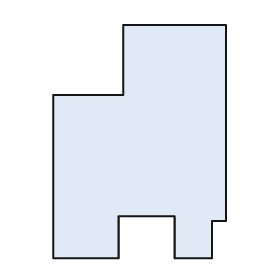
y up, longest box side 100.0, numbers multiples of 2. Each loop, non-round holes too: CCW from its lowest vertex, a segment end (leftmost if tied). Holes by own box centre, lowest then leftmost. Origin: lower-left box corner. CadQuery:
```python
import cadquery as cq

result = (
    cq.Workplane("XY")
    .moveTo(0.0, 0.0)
    .lineTo(28.0, 0.0)
    .lineTo(28.0, 18.0)
    .lineTo(52.0, 18.0)
    .lineTo(52.0, 0.0)
    .lineTo(68.0, 0.0)
    .lineTo(68.0, 16.0)
    .lineTo(74.0, 16.0)
    .lineTo(74.0, 100.0)
    .lineTo(30.0, 100.0)
    .lineTo(30.0, 70.0)
    .lineTo(0.0, 70.0)
    .close()
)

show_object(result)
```